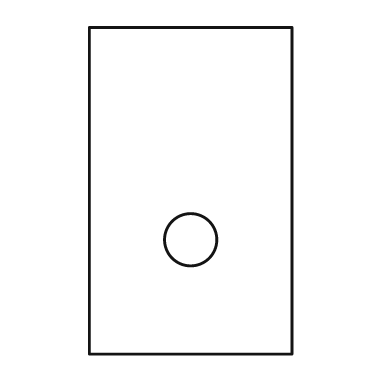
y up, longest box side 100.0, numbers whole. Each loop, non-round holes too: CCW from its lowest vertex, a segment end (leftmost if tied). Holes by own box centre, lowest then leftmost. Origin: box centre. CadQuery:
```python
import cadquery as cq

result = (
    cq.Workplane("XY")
    .moveTo(-31.0, -50.0)
    .lineTo(31.0, -50.0)
    .lineTo(31.0, 50.0)
    .lineTo(-31.0, 50.0)
    .close()
    .moveTo(0.0, -15.0)
    .circle(8.0)
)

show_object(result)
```